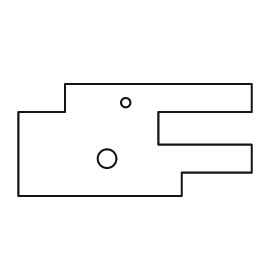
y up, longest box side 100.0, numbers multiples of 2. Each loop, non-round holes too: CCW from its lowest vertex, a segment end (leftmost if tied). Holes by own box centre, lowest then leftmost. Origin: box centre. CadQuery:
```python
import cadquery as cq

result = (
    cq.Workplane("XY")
    .moveTo(-50.0, -24.0)
    .lineTo(20.0, -24.0)
    .lineTo(20.0, -14.0)
    .lineTo(50.0, -14.0)
    .lineTo(50.0, -2.0)
    .lineTo(10.0, -2.0)
    .lineTo(10.0, 12.0)
    .lineTo(50.0, 12.0)
    .lineTo(50.0, 24.0)
    .lineTo(-30.0, 24.0)
    .lineTo(-30.0, 12.0)
    .lineTo(-50.0, 12.0)
    .close()
    .moveTo(-12.0, -8.0)
    .circle(4.0)
    .moveTo(-4.0, 16.0)
    .circle(2.0)
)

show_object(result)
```